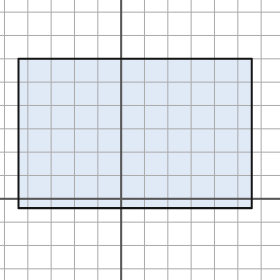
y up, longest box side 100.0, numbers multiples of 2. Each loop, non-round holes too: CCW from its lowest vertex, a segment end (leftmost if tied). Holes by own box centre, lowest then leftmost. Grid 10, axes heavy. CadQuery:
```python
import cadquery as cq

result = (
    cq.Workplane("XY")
    .moveTo(-44.0, -4.0)
    .lineTo(56.0, -4.0)
    .lineTo(56.0, 60.0)
    .lineTo(-44.0, 60.0)
    .close()
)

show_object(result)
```